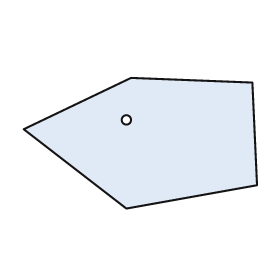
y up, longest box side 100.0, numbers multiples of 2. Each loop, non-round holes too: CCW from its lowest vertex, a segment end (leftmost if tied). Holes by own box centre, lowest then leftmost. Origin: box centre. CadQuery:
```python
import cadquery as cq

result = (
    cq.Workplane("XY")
    .moveTo(-6.0, -28.0)
    .lineTo(50.0, -18.0)
    .lineTo(48.0, 26.0)
    .lineTo(-4.0, 28.0)
    .lineTo(-50.0, 6.0)
    .close()
    .moveTo(-6.0, 10.0)
    .circle(2.0)
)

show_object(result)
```